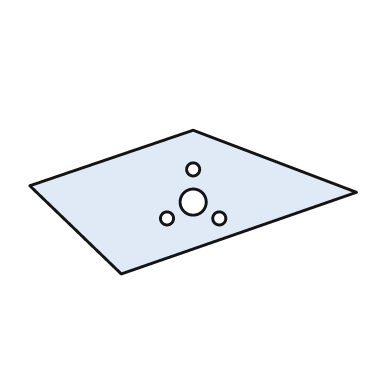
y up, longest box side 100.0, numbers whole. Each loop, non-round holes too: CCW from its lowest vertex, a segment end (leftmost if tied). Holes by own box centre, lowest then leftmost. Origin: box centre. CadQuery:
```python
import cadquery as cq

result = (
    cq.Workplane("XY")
    .moveTo(-22.0, -22.0)
    .lineTo(50.0, 3.0)
    .lineTo(0.0, 22.0)
    .lineTo(-50.0, 5.0)
    .close()
    .moveTo(-8.0, -5.0)
    .circle(2.0)
    .moveTo(8.0, -5.0)
    .circle(2.0)
    .moveTo(0.0, 0.0)
    .circle(4.0)
    .moveTo(0.0, 10.0)
    .circle(2.0)
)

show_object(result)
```